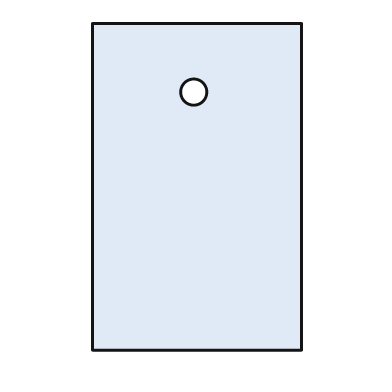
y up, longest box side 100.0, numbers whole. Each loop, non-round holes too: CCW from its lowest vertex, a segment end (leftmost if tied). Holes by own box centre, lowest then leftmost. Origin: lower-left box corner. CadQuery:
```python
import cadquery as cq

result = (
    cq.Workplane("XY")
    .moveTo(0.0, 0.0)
    .lineTo(64.0, 0.0)
    .lineTo(64.0, 100.0)
    .lineTo(0.0, 100.0)
    .close()
    .moveTo(31.0, 79.0)
    .circle(4.0)
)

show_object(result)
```